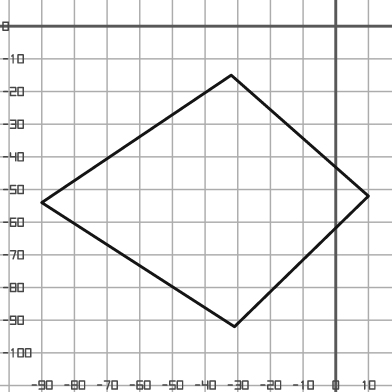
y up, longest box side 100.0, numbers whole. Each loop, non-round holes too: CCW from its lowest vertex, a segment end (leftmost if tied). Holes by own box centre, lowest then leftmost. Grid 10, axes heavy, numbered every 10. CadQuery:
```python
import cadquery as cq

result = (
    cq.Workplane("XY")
    .moveTo(-31.0, -92.0)
    .lineTo(10.0, -52.0)
    .lineTo(-32.0, -15.0)
    .lineTo(-90.0, -54.0)
    .close()
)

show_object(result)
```